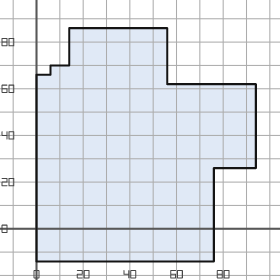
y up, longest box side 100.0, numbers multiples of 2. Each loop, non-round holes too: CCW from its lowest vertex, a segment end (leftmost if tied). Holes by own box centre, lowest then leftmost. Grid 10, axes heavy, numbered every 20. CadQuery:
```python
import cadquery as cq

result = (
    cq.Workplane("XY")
    .moveTo(0.0, -14.0)
    .lineTo(76.0, -14.0)
    .lineTo(76.0, 26.0)
    .lineTo(94.0, 26.0)
    .lineTo(94.0, 62.0)
    .lineTo(56.0, 62.0)
    .lineTo(56.0, 86.0)
    .lineTo(14.0, 86.0)
    .lineTo(14.0, 70.0)
    .lineTo(6.0, 70.0)
    .lineTo(6.0, 66.0)
    .lineTo(0.0, 66.0)
    .close()
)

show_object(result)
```